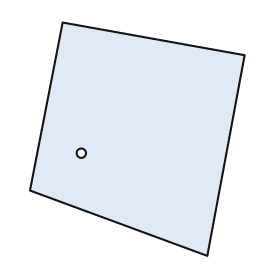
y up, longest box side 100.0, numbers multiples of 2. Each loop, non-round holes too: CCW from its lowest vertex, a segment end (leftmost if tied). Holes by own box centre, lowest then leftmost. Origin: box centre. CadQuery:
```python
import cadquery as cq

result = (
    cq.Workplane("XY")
    .moveTo(30.0, -50.0)
    .lineTo(46.0, 36.0)
    .lineTo(-32.0, 50.0)
    .lineTo(-46.0, -22.0)
    .close()
    .moveTo(-24.0, -6.0)
    .circle(2.0)
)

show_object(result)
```